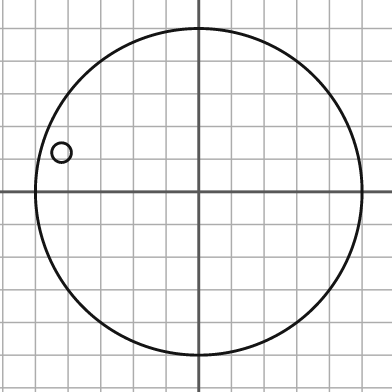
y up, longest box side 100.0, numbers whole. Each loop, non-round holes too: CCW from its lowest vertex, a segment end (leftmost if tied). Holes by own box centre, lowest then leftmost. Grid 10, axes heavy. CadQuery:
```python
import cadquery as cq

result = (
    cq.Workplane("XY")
    .moveTo(0.0, 0.0)
    .circle(50.0)
    .moveTo(-42.0, 12.0)
    .circle(3.0)
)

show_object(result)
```